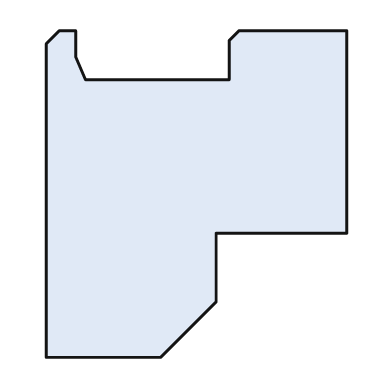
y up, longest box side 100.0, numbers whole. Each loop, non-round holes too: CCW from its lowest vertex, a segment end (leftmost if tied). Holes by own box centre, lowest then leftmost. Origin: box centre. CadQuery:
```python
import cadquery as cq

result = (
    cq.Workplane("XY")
    .moveTo(-46.0, -50.0)
    .lineTo(-11.0, -50.0)
    .lineTo(6.0, -33.0)
    .lineTo(6.0, -12.0)
    .lineTo(46.0, -12.0)
    .lineTo(46.0, 50.0)
    .lineTo(13.0, 50.0)
    .lineTo(10.0, 47.0)
    .lineTo(10.0, 35.0)
    .lineTo(-34.0, 35.0)
    .lineTo(-37.0, 42.0)
    .lineTo(-37.0, 50.0)
    .lineTo(-42.0, 50.0)
    .lineTo(-46.0, 46.0)
    .close()
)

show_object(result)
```